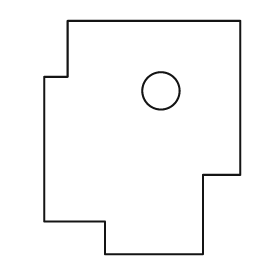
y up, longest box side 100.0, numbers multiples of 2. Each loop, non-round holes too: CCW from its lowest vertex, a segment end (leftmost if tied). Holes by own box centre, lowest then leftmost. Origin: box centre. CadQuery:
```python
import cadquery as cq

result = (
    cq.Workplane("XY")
    .moveTo(-16.0, -50.0)
    .lineTo(26.0, -50.0)
    .lineTo(26.0, -16.0)
    .lineTo(42.0, -16.0)
    .lineTo(42.0, 50.0)
    .lineTo(-32.0, 50.0)
    .lineTo(-32.0, 26.0)
    .lineTo(-42.0, 26.0)
    .lineTo(-42.0, -36.0)
    .lineTo(-16.0, -36.0)
    .close()
    .moveTo(8.0, 20.0)
    .circle(8.0)
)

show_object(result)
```